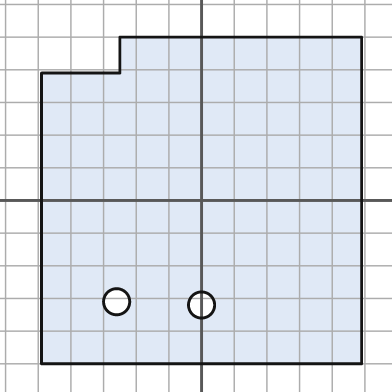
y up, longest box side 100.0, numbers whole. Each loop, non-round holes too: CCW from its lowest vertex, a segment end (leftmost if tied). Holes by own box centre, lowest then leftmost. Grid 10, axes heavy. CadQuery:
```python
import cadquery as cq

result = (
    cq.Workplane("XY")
    .moveTo(-49.0, -50.0)
    .lineTo(49.0, -50.0)
    .lineTo(49.0, 50.0)
    .lineTo(-25.0, 50.0)
    .lineTo(-25.0, 39.0)
    .lineTo(-49.0, 39.0)
    .close()
    .moveTo(0.0, -32.0)
    .circle(4.0)
    .moveTo(-26.0, -31.0)
    .circle(4.0)
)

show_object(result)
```